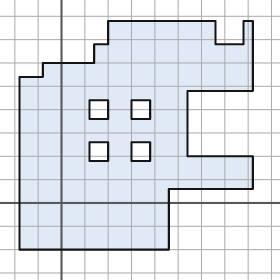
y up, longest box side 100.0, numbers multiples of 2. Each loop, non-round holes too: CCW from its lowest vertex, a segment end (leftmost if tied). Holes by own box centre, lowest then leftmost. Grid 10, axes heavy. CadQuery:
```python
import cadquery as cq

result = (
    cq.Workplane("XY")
    .moveTo(-18.0, -20.0)
    .lineTo(46.0, -20.0)
    .lineTo(46.0, 6.0)
    .lineTo(82.0, 6.0)
    .lineTo(82.0, 20.0)
    .lineTo(54.0, 20.0)
    .lineTo(54.0, 48.0)
    .lineTo(82.0, 48.0)
    .lineTo(82.0, 78.0)
    .lineTo(78.0, 78.0)
    .lineTo(78.0, 68.0)
    .lineTo(66.0, 68.0)
    .lineTo(66.0, 78.0)
    .lineTo(20.0, 78.0)
    .lineTo(20.0, 68.0)
    .lineTo(14.0, 68.0)
    .lineTo(14.0, 60.0)
    .lineTo(-8.0, 60.0)
    .lineTo(-8.0, 54.0)
    .lineTo(-18.0, 54.0)
    .close()
    .moveTo(12.0, 18.0)
    .lineTo(20.0, 18.0)
    .lineTo(20.0, 26.0)
    .lineTo(12.0, 26.0)
    .close()
    .moveTo(30.0, 18.0)
    .lineTo(38.0, 18.0)
    .lineTo(38.0, 26.0)
    .lineTo(30.0, 26.0)
    .close()
    .moveTo(12.0, 36.0)
    .lineTo(20.0, 36.0)
    .lineTo(20.0, 44.0)
    .lineTo(12.0, 44.0)
    .close()
    .moveTo(30.0, 36.0)
    .lineTo(38.0, 36.0)
    .lineTo(38.0, 44.0)
    .lineTo(30.0, 44.0)
    .close()
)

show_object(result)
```